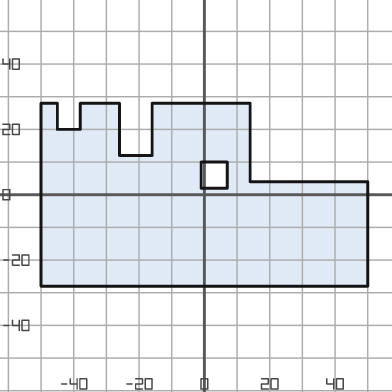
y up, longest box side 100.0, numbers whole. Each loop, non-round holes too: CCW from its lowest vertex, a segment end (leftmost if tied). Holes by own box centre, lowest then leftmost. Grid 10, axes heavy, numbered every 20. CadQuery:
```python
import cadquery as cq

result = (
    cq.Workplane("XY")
    .moveTo(-50.0, -28.0)
    .lineTo(50.0, -28.0)
    .lineTo(50.0, 4.0)
    .lineTo(14.0, 4.0)
    .lineTo(14.0, 28.0)
    .lineTo(-16.0, 28.0)
    .lineTo(-16.0, 12.0)
    .lineTo(-26.0, 12.0)
    .lineTo(-26.0, 28.0)
    .lineTo(-38.0, 28.0)
    .lineTo(-38.0, 20.0)
    .lineTo(-45.0, 20.0)
    .lineTo(-45.0, 28.0)
    .lineTo(-50.0, 28.0)
    .close()
    .moveTo(-1.0, 2.0)
    .lineTo(7.0, 2.0)
    .lineTo(7.0, 10.0)
    .lineTo(-1.0, 10.0)
    .close()
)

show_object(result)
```